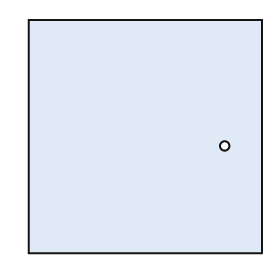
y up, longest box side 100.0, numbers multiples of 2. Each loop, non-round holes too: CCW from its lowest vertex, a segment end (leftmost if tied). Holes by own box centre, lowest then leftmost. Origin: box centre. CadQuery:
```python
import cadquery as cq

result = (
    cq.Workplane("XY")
    .moveTo(-50.0, -50.0)
    .lineTo(50.0, -50.0)
    .lineTo(50.0, 50.0)
    .lineTo(-50.0, 50.0)
    .close()
    .moveTo(34.0, -4.0)
    .circle(2.0)
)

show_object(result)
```